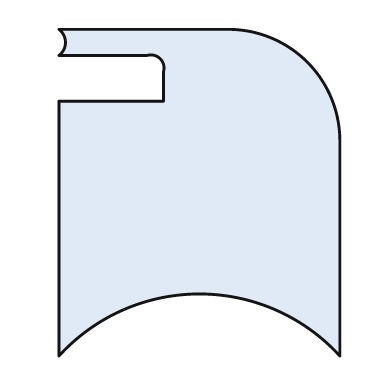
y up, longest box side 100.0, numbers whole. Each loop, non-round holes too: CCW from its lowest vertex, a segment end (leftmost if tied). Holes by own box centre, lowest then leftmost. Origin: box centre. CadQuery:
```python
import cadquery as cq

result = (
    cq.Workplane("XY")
    .moveTo(-43.0, -50.0)
    .threePointArc((0.0, -31.0), (43.0, -50.0))
    .lineTo(43.0, 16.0)
    .threePointArc((33.0, 40.0), (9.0, 50.0))
    .lineTo(-43.0, 50.0)
    .threePointArc((-41.0, 46.0), (-43.0, 42.0))
    .lineTo(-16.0, 42.0)
    .threePointArc((-12.0, 41.0), (-11.0, 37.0))
    .lineTo(-11.0, 28.0)
    .lineTo(-43.0, 28.0)
    .close()
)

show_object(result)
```